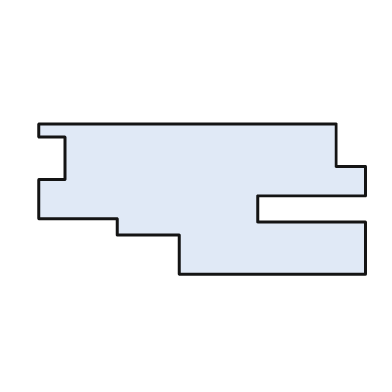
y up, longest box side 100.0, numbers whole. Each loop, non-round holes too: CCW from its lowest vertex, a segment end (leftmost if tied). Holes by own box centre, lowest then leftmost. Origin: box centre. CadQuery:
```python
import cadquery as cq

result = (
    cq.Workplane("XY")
    .moveTo(-7.0, -23.0)
    .lineTo(50.0, -23.0)
    .lineTo(50.0, -7.0)
    .lineTo(17.0, -7.0)
    .lineTo(17.0, 1.0)
    .lineTo(50.0, 1.0)
    .lineTo(50.0, 10.0)
    .lineTo(41.0, 10.0)
    .lineTo(41.0, 23.0)
    .lineTo(-50.0, 23.0)
    .lineTo(-50.0, 19.0)
    .lineTo(-42.0, 19.0)
    .lineTo(-42.0, 6.0)
    .lineTo(-50.0, 6.0)
    .lineTo(-50.0, -6.0)
    .lineTo(-26.0, -6.0)
    .lineTo(-26.0, -11.0)
    .lineTo(-7.0, -11.0)
    .close()
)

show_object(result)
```